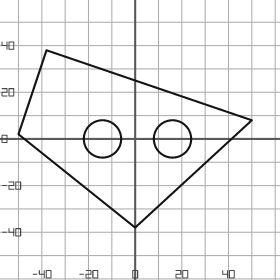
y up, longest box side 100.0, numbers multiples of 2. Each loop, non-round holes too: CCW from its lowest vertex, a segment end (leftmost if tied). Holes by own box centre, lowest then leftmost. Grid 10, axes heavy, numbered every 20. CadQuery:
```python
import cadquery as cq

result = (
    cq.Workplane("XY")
    .moveTo(0.0, -38.0)
    .lineTo(50.0, 8.0)
    .lineTo(-38.0, 38.0)
    .lineTo(-50.0, 2.0)
    .close()
    .moveTo(-14.0, 0.0)
    .circle(8.0)
    .moveTo(16.0, 0.0)
    .circle(8.0)
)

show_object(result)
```